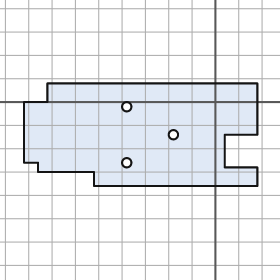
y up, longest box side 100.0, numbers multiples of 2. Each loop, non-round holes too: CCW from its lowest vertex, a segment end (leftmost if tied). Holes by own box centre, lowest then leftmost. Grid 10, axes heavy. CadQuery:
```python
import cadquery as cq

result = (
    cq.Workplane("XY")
    .moveTo(-52.0, -36.0)
    .lineTo(18.0, -36.0)
    .lineTo(18.0, -28.0)
    .lineTo(4.0, -28.0)
    .lineTo(4.0, -14.0)
    .lineTo(18.0, -14.0)
    .lineTo(18.0, 8.0)
    .lineTo(-72.0, 8.0)
    .lineTo(-72.0, 0.0)
    .lineTo(-82.0, 0.0)
    .lineTo(-82.0, -26.0)
    .lineTo(-76.0, -26.0)
    .lineTo(-76.0, -30.0)
    .lineTo(-52.0, -30.0)
    .close()
    .moveTo(-38.0, -26.0)
    .circle(2.0)
    .moveTo(-18.0, -14.0)
    .circle(2.0)
    .moveTo(-38.0, -2.0)
    .circle(2.0)
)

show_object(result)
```